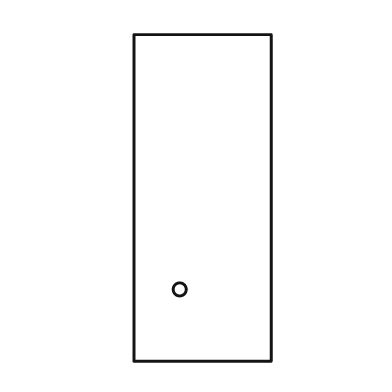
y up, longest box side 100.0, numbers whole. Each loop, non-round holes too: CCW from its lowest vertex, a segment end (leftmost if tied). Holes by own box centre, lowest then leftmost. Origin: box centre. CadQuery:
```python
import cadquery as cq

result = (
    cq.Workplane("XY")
    .moveTo(-21.0, -50.0)
    .lineTo(21.0, -50.0)
    .lineTo(21.0, 50.0)
    .lineTo(-21.0, 50.0)
    .close()
    .moveTo(-7.0, -28.0)
    .circle(2.0)
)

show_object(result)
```